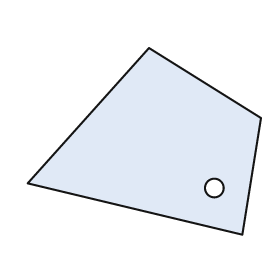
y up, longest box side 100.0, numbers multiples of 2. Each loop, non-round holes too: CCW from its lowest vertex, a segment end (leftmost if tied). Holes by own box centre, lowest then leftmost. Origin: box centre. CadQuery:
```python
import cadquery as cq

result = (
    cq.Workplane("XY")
    .moveTo(42.0, -40.0)
    .lineTo(50.0, 10.0)
    .lineTo(2.0, 40.0)
    .lineTo(-50.0, -18.0)
    .close()
    .moveTo(30.0, -20.0)
    .circle(4.0)
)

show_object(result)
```